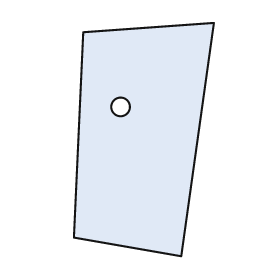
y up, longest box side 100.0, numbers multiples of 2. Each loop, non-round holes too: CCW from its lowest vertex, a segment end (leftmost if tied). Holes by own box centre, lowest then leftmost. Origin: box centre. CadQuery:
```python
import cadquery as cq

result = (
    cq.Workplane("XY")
    .moveTo(16.0, -50.0)
    .lineTo(30.0, 50.0)
    .lineTo(-26.0, 46.0)
    .lineTo(-30.0, -42.0)
    .close()
    .moveTo(-10.0, 14.0)
    .circle(4.0)
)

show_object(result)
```